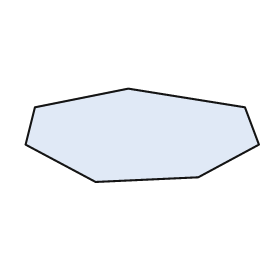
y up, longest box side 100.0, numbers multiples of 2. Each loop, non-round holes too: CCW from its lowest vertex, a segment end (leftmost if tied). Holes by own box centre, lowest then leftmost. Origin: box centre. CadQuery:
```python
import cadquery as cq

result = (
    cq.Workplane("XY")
    .moveTo(-20.0, -20.0)
    .lineTo(24.0, -18.0)
    .lineTo(50.0, -4.0)
    .lineTo(44.0, 12.0)
    .lineTo(-6.0, 20.0)
    .lineTo(-46.0, 12.0)
    .lineTo(-50.0, -4.0)
    .close()
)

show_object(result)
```